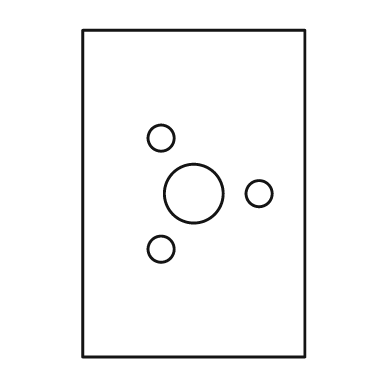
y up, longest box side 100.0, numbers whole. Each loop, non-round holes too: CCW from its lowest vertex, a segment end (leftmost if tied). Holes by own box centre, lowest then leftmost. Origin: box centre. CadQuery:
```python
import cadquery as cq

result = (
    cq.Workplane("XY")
    .moveTo(-34.0, -50.0)
    .lineTo(34.0, -50.0)
    .lineTo(34.0, 50.0)
    .lineTo(-34.0, 50.0)
    .close()
    .moveTo(-10.0, -17.0)
    .circle(4.0)
    .moveTo(0.0, 0.0)
    .circle(9.0)
    .moveTo(20.0, 0.0)
    .circle(4.0)
    .moveTo(-10.0, 17.0)
    .circle(4.0)
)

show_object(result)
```